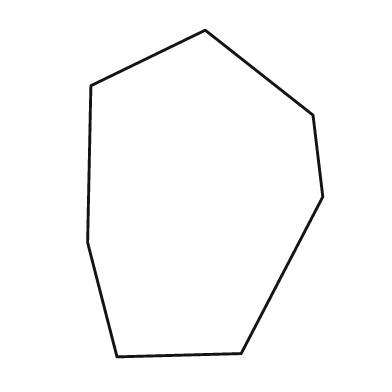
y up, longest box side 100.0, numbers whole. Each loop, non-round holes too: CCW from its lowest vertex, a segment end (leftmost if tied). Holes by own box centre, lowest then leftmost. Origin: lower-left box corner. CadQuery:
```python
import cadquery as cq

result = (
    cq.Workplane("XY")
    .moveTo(9.0, 0.0)
    .lineTo(47.0, 1.0)
    .lineTo(72.0, 49.0)
    .lineTo(69.0, 74.0)
    .lineTo(36.0, 100.0)
    .lineTo(1.0, 83.0)
    .lineTo(0.0, 35.0)
    .close()
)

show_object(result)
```